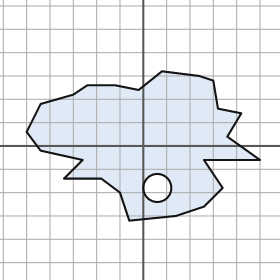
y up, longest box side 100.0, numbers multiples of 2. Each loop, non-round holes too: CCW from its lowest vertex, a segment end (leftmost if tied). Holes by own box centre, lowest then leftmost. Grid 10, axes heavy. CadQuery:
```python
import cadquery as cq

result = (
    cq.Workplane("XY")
    .moveTo(-6.0, -32.0)
    .lineTo(14.0, -30.0)
    .lineTo(26.0, -26.0)
    .lineTo(34.0, -18.0)
    .lineTo(26.0, -6.0)
    .lineTo(50.0, -6.0)
    .lineTo(36.0, 4.0)
    .lineTo(42.0, 14.0)
    .lineTo(32.0, 16.0)
    .lineTo(30.0, 28.0)
    .lineTo(24.0, 30.0)
    .lineTo(8.0, 32.0)
    .lineTo(-2.0, 24.0)
    .lineTo(-12.0, 26.0)
    .lineTo(-24.0, 26.0)
    .lineTo(-30.0, 22.0)
    .lineTo(-44.0, 18.0)
    .lineTo(-50.0, 6.0)
    .lineTo(-44.0, -2.0)
    .lineTo(-26.0, -6.0)
    .lineTo(-34.0, -14.0)
    .lineTo(-18.0, -14.0)
    .lineTo(-10.0, -20.0)
    .close()
    .moveTo(6.0, -18.0)
    .circle(6.0)
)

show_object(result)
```